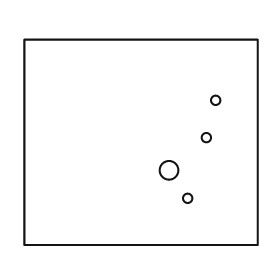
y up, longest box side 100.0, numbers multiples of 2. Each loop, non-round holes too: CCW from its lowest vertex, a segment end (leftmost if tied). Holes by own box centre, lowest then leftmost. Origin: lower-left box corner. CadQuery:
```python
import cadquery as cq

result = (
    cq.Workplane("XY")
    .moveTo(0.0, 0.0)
    .lineTo(100.0, 0.0)
    .lineTo(100.0, 88.0)
    .lineTo(0.0, 88.0)
    .close()
    .moveTo(70.0, 20.0)
    .circle(2.0)
    .moveTo(62.0, 32.0)
    .circle(4.0)
    .moveTo(78.0, 46.0)
    .circle(2.0)
    .moveTo(82.0, 62.0)
    .circle(2.0)
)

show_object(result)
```